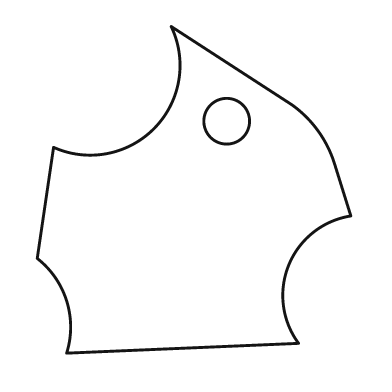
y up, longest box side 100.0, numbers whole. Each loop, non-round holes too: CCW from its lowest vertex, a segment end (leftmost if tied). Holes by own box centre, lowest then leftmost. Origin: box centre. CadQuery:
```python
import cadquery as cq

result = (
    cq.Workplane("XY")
    .moveTo(-39.0, -50.0)
    .lineTo(32.0, -47.0)
    .threePointArc((29.0, -23.0), (48.0, -8.0))
    .lineTo(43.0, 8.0)
    .threePointArc((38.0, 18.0), (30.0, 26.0))
    .lineTo(-7.0, 50.0)
    .threePointArc((-12.0, 19.0), (-43.0, 13.0))
    .lineTo(-48.0, -21.0)
    .threePointArc((-39.0, -34.0), (-39.0, -50.0))
    .close()
    .moveTo(10.0, 21.0)
    .circle(7.0)
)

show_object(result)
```